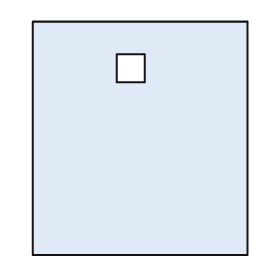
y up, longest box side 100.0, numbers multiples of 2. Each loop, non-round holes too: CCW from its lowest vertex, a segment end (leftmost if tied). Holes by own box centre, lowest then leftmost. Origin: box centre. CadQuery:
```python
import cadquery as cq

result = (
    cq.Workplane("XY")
    .moveTo(-46.0, -50.0)
    .lineTo(46.0, -50.0)
    .lineTo(46.0, 50.0)
    .lineTo(-46.0, 50.0)
    .close()
    .moveTo(-10.0, 24.0)
    .lineTo(2.0, 24.0)
    .lineTo(2.0, 36.0)
    .lineTo(-10.0, 36.0)
    .close()
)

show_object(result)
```